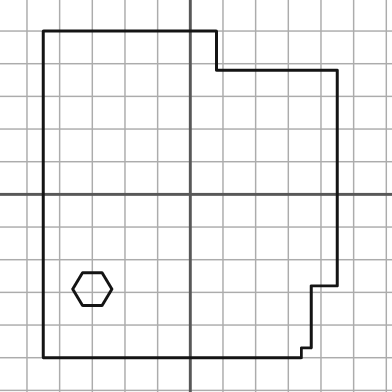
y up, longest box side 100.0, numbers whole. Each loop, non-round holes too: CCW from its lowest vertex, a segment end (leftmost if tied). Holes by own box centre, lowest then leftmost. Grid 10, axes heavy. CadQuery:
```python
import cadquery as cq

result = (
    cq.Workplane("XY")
    .moveTo(-45.0, -50.0)
    .lineTo(34.0, -50.0)
    .lineTo(34.0, -47.0)
    .lineTo(37.0, -47.0)
    .lineTo(37.0, -28.0)
    .lineTo(45.0, -28.0)
    .lineTo(45.0, 38.0)
    .lineTo(8.0, 38.0)
    .lineTo(8.0, 50.0)
    .lineTo(-45.0, 50.0)
    .close()
    .moveTo(-33.0, -34.0)
    .lineTo(-27.0, -34.0)
    .lineTo(-24.0, -29.0)
    .lineTo(-27.0, -24.0)
    .lineTo(-33.0, -24.0)
    .lineTo(-36.0, -29.0)
    .close()
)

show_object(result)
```